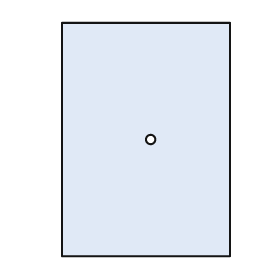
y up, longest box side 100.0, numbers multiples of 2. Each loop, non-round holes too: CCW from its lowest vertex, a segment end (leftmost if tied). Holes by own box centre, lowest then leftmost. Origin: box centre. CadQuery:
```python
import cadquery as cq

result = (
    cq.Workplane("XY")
    .moveTo(-36.0, -50.0)
    .lineTo(36.0, -50.0)
    .lineTo(36.0, 50.0)
    .lineTo(-36.0, 50.0)
    .close()
    .moveTo(2.0, 0.0)
    .circle(2.0)
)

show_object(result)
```